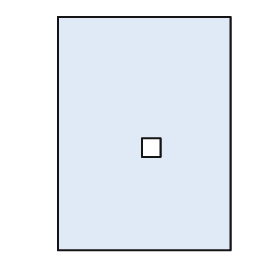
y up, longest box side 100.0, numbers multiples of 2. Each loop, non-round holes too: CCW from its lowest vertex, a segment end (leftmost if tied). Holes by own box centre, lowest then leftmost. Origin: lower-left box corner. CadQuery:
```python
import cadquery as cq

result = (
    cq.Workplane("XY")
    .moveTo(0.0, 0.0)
    .lineTo(74.0, 0.0)
    .lineTo(74.0, 100.0)
    .lineTo(0.0, 100.0)
    .close()
    .moveTo(36.0, 40.0)
    .lineTo(44.0, 40.0)
    .lineTo(44.0, 48.0)
    .lineTo(36.0, 48.0)
    .close()
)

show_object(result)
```